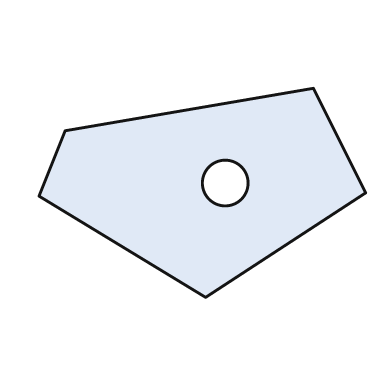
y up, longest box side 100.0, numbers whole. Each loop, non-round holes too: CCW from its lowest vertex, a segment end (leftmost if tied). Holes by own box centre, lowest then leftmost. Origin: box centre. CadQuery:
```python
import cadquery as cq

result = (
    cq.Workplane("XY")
    .moveTo(1.0, -32.0)
    .lineTo(50.0, 0.0)
    .lineTo(34.0, 32.0)
    .lineTo(-42.0, 19.0)
    .lineTo(-50.0, -1.0)
    .close()
    .moveTo(7.0, 3.0)
    .circle(7.0)
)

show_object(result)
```